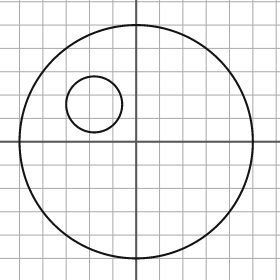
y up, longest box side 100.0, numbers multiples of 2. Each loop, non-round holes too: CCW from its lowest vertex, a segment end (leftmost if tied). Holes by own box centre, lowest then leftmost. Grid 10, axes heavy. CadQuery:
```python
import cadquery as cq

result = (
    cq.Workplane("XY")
    .moveTo(0.0, 0.0)
    .circle(50.0)
    .moveTo(-18.0, 16.0)
    .circle(12.0)
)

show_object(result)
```